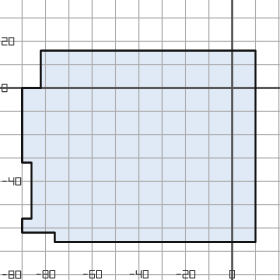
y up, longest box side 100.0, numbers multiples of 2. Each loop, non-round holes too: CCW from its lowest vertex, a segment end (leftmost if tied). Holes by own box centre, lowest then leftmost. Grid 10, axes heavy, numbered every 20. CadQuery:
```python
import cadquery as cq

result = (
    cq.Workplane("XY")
    .moveTo(-76.0, -66.0)
    .lineTo(10.0, -66.0)
    .lineTo(10.0, 16.0)
    .lineTo(-82.0, 16.0)
    .lineTo(-82.0, 0.0)
    .lineTo(-90.0, 0.0)
    .lineTo(-90.0, -32.0)
    .lineTo(-86.0, -32.0)
    .lineTo(-86.0, -56.0)
    .lineTo(-90.0, -56.0)
    .lineTo(-90.0, -62.0)
    .lineTo(-76.0, -62.0)
    .close()
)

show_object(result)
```